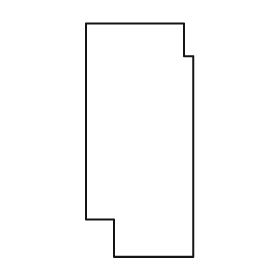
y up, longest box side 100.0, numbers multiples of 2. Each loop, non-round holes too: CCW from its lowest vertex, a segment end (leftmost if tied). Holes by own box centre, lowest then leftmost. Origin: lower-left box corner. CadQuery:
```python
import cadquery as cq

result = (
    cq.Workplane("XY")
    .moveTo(12.0, 0.0)
    .lineTo(46.0, 0.0)
    .lineTo(46.0, 86.0)
    .lineTo(42.0, 86.0)
    .lineTo(42.0, 100.0)
    .lineTo(0.0, 100.0)
    .lineTo(0.0, 16.0)
    .lineTo(12.0, 16.0)
    .close()
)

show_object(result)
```